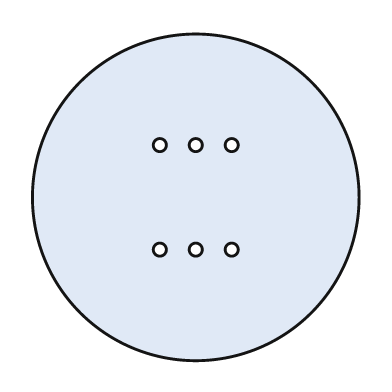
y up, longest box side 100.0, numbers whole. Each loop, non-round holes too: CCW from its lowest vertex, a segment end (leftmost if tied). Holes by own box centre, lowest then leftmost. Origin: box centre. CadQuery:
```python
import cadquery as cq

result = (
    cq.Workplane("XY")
    .moveTo(0.0, 0.0)
    .circle(50.0)
    .moveTo(-11.0, -16.0)
    .circle(2.0)
    .moveTo(0.0, -16.0)
    .circle(2.0)
    .moveTo(11.0, -16.0)
    .circle(2.0)
    .moveTo(-11.0, 16.0)
    .circle(2.0)
    .moveTo(0.0, 16.0)
    .circle(2.0)
    .moveTo(11.0, 16.0)
    .circle(2.0)
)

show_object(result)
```